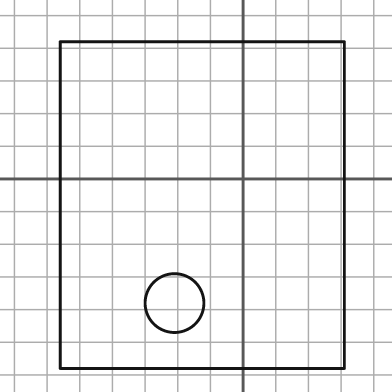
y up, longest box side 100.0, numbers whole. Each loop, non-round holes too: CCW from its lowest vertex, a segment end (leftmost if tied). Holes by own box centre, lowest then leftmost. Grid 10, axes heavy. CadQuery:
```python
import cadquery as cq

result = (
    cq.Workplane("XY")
    .moveTo(-56.0, -58.0)
    .lineTo(31.0, -58.0)
    .lineTo(31.0, 42.0)
    .lineTo(-56.0, 42.0)
    .close()
    .moveTo(-21.0, -38.0)
    .circle(9.0)
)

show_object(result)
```